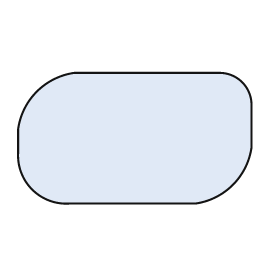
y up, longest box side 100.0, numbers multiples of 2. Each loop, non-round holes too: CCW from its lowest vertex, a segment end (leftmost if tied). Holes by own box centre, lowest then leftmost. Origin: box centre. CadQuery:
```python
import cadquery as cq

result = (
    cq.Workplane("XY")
    .moveTo(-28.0, -28.0)
    .lineTo(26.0, -28.0)
    .threePointArc((42.0, -20.0), (50.0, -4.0))
    .lineTo(50.0, 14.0)
    .threePointArc((46.0, 24.0), (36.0, 28.0))
    .lineTo(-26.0, 28.0)
    .threePointArc((-42.0, 20.0), (-50.0, 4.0))
    .lineTo(-50.0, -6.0)
    .threePointArc((-44.0, -22.0), (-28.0, -28.0))
    .close()
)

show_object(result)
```